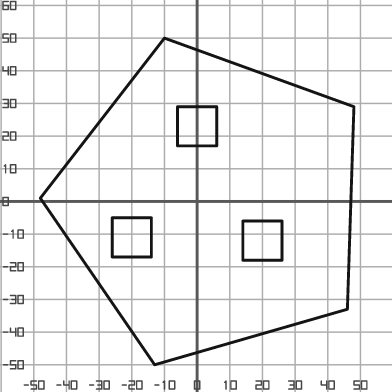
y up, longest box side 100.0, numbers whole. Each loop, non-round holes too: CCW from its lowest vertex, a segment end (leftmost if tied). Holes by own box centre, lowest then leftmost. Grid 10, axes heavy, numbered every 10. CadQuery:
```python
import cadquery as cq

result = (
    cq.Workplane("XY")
    .moveTo(-13.0, -50.0)
    .lineTo(46.0, -33.0)
    .lineTo(48.0, 29.0)
    .lineTo(-10.0, 50.0)
    .lineTo(-48.0, 1.0)
    .close()
    .moveTo(14.0, -18.0)
    .lineTo(26.0, -18.0)
    .lineTo(26.0, -6.0)
    .lineTo(14.0, -6.0)
    .close()
    .moveTo(-26.0, -17.0)
    .lineTo(-14.0, -17.0)
    .lineTo(-14.0, -5.0)
    .lineTo(-26.0, -5.0)
    .close()
    .moveTo(-6.0, 17.0)
    .lineTo(6.0, 17.0)
    .lineTo(6.0, 29.0)
    .lineTo(-6.0, 29.0)
    .close()
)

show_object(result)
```